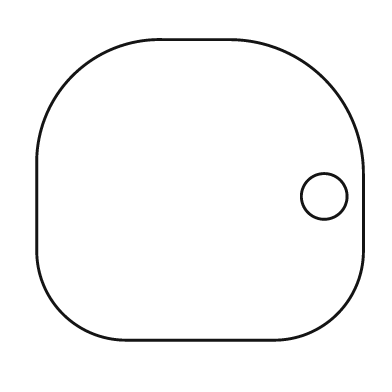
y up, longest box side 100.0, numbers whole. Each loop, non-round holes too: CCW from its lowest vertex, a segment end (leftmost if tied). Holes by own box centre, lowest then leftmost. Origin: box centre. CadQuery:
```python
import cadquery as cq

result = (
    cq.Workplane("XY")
    .moveTo(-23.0, -46.0)
    .lineTo(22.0, -46.0)
    .threePointArc((42.0, -38.0), (50.0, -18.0))
    .lineTo(50.0, 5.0)
    .threePointArc((38.0, 34.0), (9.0, 46.0))
    .lineTo(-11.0, 46.0)
    .threePointArc((-39.0, 35.0), (-50.0, 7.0))
    .lineTo(-50.0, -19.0)
    .threePointArc((-42.0, -38.0), (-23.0, -46.0))
    .close()
    .moveTo(38.0, -2.0)
    .circle(7.0)
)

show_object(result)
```